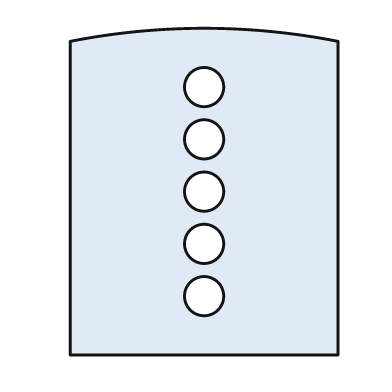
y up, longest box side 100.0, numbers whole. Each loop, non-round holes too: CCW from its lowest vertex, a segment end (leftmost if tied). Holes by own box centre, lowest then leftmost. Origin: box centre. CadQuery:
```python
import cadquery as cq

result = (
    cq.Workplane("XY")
    .moveTo(-41.0, -50.0)
    .lineTo(41.0, -50.0)
    .lineTo(41.0, 46.0)
    .threePointArc((0.0, 50.0), (-41.0, 46.0))
    .close()
    .moveTo(0.0, -32.0)
    .circle(6.0)
    .moveTo(0.0, -16.0)
    .circle(6.0)
    .moveTo(0.0, 0.0)
    .circle(6.0)
    .moveTo(0.0, 16.0)
    .circle(6.0)
    .moveTo(0.0, 32.0)
    .circle(6.0)
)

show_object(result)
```